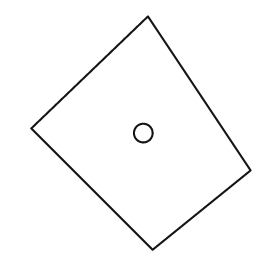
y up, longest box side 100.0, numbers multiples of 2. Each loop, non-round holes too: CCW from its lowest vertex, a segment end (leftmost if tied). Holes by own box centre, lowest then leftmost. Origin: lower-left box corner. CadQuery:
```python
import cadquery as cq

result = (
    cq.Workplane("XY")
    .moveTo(52.0, 0.0)
    .lineTo(94.0, 34.0)
    .lineTo(50.0, 100.0)
    .lineTo(0.0, 52.0)
    .close()
    .moveTo(48.0, 50.0)
    .circle(4.0)
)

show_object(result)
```